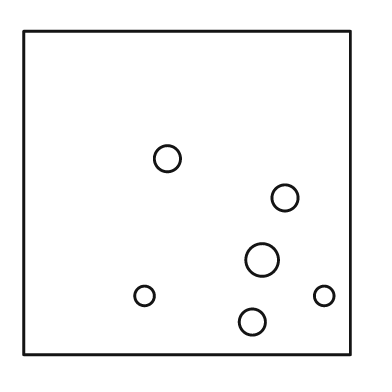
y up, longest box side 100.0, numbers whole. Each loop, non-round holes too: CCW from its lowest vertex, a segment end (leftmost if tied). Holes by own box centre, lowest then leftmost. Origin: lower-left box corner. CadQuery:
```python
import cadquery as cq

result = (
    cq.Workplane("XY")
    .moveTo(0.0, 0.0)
    .lineTo(100.0, 0.0)
    .lineTo(100.0, 99.0)
    .lineTo(0.0, 99.0)
    .close()
    .moveTo(70.0, 10.0)
    .circle(4.0)
    .moveTo(37.0, 18.0)
    .circle(3.0)
    .moveTo(92.0, 18.0)
    .circle(3.0)
    .moveTo(73.0, 29.0)
    .circle(5.0)
    .moveTo(80.0, 48.0)
    .circle(4.0)
    .moveTo(44.0, 60.0)
    .circle(4.0)
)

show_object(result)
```